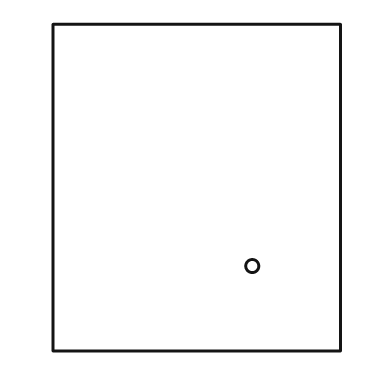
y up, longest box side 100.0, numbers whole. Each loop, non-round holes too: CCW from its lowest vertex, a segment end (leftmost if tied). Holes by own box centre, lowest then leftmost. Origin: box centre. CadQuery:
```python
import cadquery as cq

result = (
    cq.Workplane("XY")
    .moveTo(-44.0, -50.0)
    .lineTo(44.0, -50.0)
    .lineTo(44.0, 50.0)
    .lineTo(-44.0, 50.0)
    .close()
    .moveTo(17.0, -24.0)
    .circle(2.0)
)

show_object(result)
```